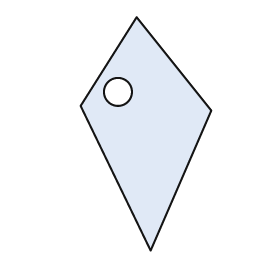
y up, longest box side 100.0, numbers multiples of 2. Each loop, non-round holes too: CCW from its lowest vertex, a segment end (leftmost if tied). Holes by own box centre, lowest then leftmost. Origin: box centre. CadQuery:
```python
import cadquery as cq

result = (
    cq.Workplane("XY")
    .moveTo(2.0, -50.0)
    .lineTo(28.0, 10.0)
    .lineTo(-4.0, 50.0)
    .lineTo(-28.0, 12.0)
    .close()
    .moveTo(-12.0, 18.0)
    .circle(6.0)
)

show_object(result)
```